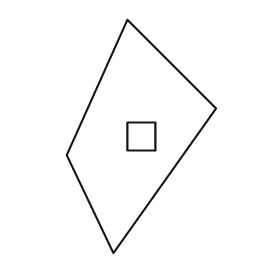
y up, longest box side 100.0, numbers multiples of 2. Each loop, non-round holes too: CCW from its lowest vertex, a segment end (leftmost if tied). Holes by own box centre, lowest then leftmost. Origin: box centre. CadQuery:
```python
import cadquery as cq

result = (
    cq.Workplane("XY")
    .moveTo(-12.0, -50.0)
    .lineTo(32.0, 12.0)
    .lineTo(-6.0, 50.0)
    .lineTo(-32.0, -8.0)
    .close()
    .moveTo(-6.0, -6.0)
    .lineTo(6.0, -6.0)
    .lineTo(6.0, 6.0)
    .lineTo(-6.0, 6.0)
    .close()
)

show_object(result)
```